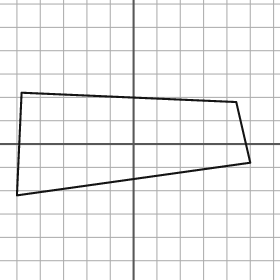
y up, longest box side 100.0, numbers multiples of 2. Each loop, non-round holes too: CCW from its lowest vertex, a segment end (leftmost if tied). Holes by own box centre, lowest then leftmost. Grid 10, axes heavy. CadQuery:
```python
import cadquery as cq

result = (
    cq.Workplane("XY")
    .moveTo(-50.0, -22.0)
    .lineTo(50.0, -8.0)
    .lineTo(44.0, 18.0)
    .lineTo(-48.0, 22.0)
    .close()
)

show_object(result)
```